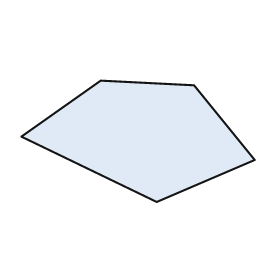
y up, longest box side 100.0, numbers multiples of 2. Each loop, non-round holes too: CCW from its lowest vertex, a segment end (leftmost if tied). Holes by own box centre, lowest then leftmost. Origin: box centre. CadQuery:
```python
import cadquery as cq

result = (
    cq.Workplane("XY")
    .moveTo(8.0, -26.0)
    .lineTo(50.0, -8.0)
    .lineTo(24.0, 24.0)
    .lineTo(-16.0, 26.0)
    .lineTo(-50.0, 2.0)
    .close()
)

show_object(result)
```